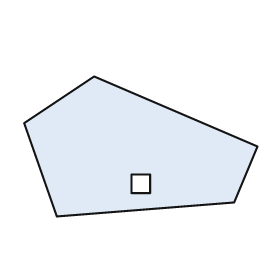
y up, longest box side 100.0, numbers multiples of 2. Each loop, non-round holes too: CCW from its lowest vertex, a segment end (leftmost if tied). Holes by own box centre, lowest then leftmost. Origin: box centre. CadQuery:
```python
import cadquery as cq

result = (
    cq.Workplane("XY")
    .moveTo(-36.0, -30.0)
    .lineTo(40.0, -24.0)
    .lineTo(50.0, 0.0)
    .lineTo(-20.0, 30.0)
    .lineTo(-50.0, 10.0)
    .close()
    .moveTo(-4.0, -20.0)
    .lineTo(4.0, -20.0)
    .lineTo(4.0, -12.0)
    .lineTo(-4.0, -12.0)
    .close()
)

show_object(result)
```